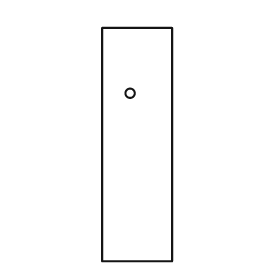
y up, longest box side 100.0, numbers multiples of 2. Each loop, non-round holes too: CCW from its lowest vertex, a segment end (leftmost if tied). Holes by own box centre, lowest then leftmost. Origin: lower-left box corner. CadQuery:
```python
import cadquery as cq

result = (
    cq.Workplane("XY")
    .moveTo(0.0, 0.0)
    .lineTo(30.0, 0.0)
    .lineTo(30.0, 100.0)
    .lineTo(0.0, 100.0)
    .close()
    .moveTo(12.0, 72.0)
    .circle(2.0)
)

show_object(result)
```